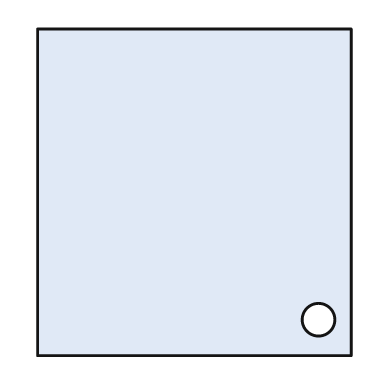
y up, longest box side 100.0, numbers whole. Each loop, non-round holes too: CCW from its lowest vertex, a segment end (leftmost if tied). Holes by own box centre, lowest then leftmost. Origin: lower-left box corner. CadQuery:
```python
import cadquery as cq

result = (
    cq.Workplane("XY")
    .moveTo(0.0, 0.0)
    .lineTo(96.0, 0.0)
    .lineTo(96.0, 100.0)
    .lineTo(0.0, 100.0)
    .close()
    .moveTo(86.0, 11.0)
    .circle(5.0)
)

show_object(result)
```